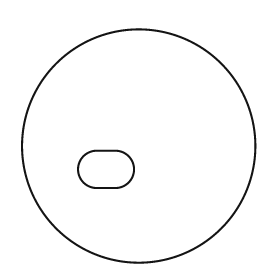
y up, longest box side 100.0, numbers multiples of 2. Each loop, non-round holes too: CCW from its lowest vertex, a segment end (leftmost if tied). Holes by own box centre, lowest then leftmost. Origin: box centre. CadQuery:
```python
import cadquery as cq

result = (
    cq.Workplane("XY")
    .moveTo(0.0, 0.0)
    .circle(50.0)
    .moveTo(-18.0, -18.0)
    .lineTo(-10.0, -18.0)
    .threePointArc((-2.0, -10.0), (-10.0, -2.0))
    .lineTo(-18.0, -2.0)
    .threePointArc((-26.0, -10.0), (-18.0, -18.0))
    .close()
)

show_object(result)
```